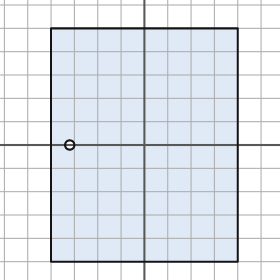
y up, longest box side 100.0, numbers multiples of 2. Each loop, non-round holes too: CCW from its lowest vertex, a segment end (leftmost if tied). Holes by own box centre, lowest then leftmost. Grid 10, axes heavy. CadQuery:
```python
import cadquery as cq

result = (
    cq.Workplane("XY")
    .moveTo(-40.0, -50.0)
    .lineTo(40.0, -50.0)
    .lineTo(40.0, 50.0)
    .lineTo(-40.0, 50.0)
    .close()
    .moveTo(-32.0, 0.0)
    .circle(2.0)
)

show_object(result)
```